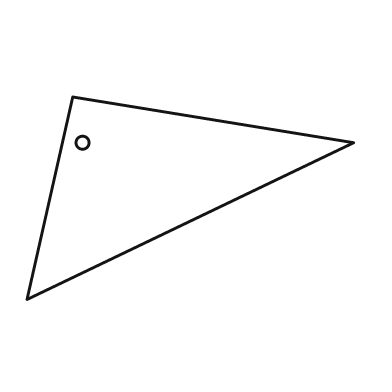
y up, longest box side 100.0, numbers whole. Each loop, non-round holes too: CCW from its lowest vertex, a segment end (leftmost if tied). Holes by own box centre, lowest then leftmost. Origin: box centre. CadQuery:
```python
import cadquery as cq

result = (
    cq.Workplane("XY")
    .moveTo(-50.0, -31.0)
    .lineTo(50.0, 17.0)
    .lineTo(-36.0, 31.0)
    .close()
    .moveTo(-33.0, 17.0)
    .circle(2.0)
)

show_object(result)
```